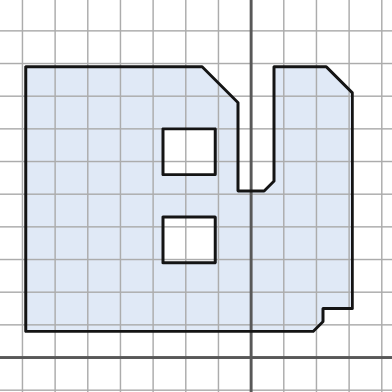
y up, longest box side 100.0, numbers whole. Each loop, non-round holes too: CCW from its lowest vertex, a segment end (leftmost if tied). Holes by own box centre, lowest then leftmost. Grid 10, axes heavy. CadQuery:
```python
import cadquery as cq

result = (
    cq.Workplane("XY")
    .moveTo(-69.0, 8.0)
    .lineTo(19.0, 8.0)
    .lineTo(22.0, 11.0)
    .lineTo(22.0, 15.0)
    .lineTo(31.0, 15.0)
    .lineTo(31.0, 81.0)
    .lineTo(23.0, 89.0)
    .lineTo(7.0, 89.0)
    .lineTo(7.0, 54.0)
    .lineTo(4.0, 51.0)
    .lineTo(-4.0, 51.0)
    .lineTo(-4.0, 78.0)
    .lineTo(-15.0, 89.0)
    .lineTo(-69.0, 89.0)
    .close()
    .moveTo(-27.0, 29.0)
    .lineTo(-11.0, 29.0)
    .lineTo(-11.0, 43.0)
    .lineTo(-27.0, 43.0)
    .close()
    .moveTo(-27.0, 56.0)
    .lineTo(-11.0, 56.0)
    .lineTo(-11.0, 70.0)
    .lineTo(-27.0, 70.0)
    .close()
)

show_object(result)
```